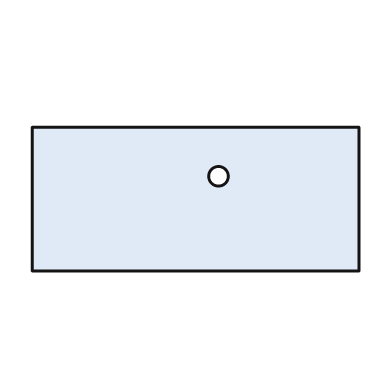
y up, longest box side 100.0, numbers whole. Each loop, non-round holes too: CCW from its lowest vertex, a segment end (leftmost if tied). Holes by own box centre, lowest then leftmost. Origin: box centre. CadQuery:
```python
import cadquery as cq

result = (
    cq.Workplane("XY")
    .moveTo(-50.0, -22.0)
    .lineTo(50.0, -22.0)
    .lineTo(50.0, 22.0)
    .lineTo(-50.0, 22.0)
    .close()
    .moveTo(7.0, 7.0)
    .circle(3.0)
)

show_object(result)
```